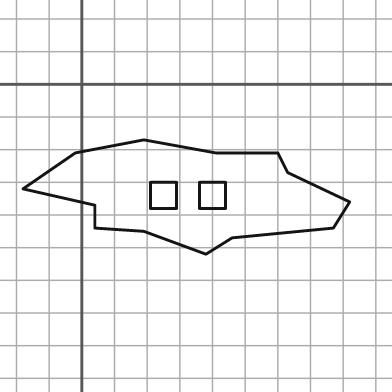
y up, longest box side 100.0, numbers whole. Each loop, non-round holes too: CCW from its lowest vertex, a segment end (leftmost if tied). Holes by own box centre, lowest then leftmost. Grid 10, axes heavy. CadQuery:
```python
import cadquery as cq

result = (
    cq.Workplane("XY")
    .moveTo(38.0, -52.0)
    .lineTo(46.0, -47.0)
    .lineTo(77.0, -44.0)
    .lineTo(82.0, -36.0)
    .lineTo(63.0, -27.0)
    .lineTo(60.0, -21.0)
    .lineTo(41.0, -21.0)
    .lineTo(19.0, -17.0)
    .lineTo(-2.0, -21.0)
    .lineTo(-18.0, -32.0)
    .lineTo(4.0, -37.0)
    .lineTo(4.0, -44.0)
    .lineTo(19.0, -45.0)
    .close()
    .moveTo(21.0, -38.0)
    .lineTo(29.0, -38.0)
    .lineTo(29.0, -30.0)
    .lineTo(21.0, -30.0)
    .close()
    .moveTo(36.0, -38.0)
    .lineTo(44.0, -38.0)
    .lineTo(44.0, -30.0)
    .lineTo(36.0, -30.0)
    .close()
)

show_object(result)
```